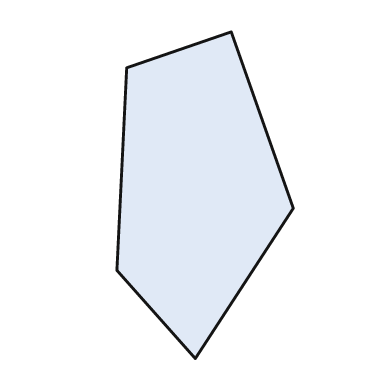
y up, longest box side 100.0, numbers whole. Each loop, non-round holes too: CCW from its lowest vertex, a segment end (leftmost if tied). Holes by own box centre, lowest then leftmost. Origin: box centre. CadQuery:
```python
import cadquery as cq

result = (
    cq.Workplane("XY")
    .moveTo(-3.0, -50.0)
    .lineTo(27.0, -4.0)
    .lineTo(8.0, 50.0)
    .lineTo(-24.0, 39.0)
    .lineTo(-27.0, -23.0)
    .close()
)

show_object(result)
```